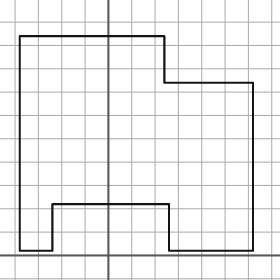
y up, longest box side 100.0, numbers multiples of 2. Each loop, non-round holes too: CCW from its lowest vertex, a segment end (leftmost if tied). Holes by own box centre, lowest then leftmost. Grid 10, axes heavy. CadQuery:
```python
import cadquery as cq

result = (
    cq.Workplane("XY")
    .moveTo(-38.0, 2.0)
    .lineTo(-24.0, 2.0)
    .lineTo(-24.0, 22.0)
    .lineTo(26.0, 22.0)
    .lineTo(26.0, 2.0)
    .lineTo(62.0, 2.0)
    .lineTo(62.0, 74.0)
    .lineTo(24.0, 74.0)
    .lineTo(24.0, 94.0)
    .lineTo(-38.0, 94.0)
    .close()
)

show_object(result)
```